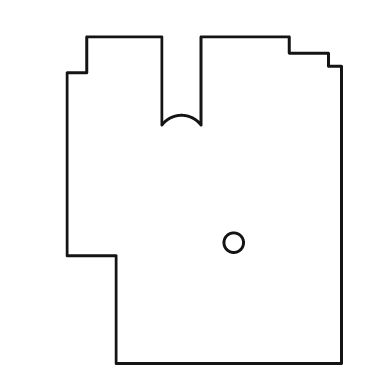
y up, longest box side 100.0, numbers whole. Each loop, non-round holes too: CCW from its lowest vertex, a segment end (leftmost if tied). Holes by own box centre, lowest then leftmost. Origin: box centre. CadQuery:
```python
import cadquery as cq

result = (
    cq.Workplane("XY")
    .moveTo(-27.0, -50.0)
    .lineTo(42.0, -50.0)
    .lineTo(42.0, 41.0)
    .lineTo(38.0, 41.0)
    .lineTo(38.0, 45.0)
    .lineTo(26.0, 45.0)
    .lineTo(26.0, 50.0)
    .lineTo(-1.0, 50.0)
    .lineTo(-1.0, 23.0)
    .threePointArc((-7.0, 26.0), (-13.0, 23.0))
    .lineTo(-13.0, 50.0)
    .lineTo(-36.0, 50.0)
    .lineTo(-36.0, 39.0)
    .lineTo(-42.0, 39.0)
    .lineTo(-42.0, -17.0)
    .lineTo(-27.0, -17.0)
    .close()
    .moveTo(9.0, -13.0)
    .circle(3.0)
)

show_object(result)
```